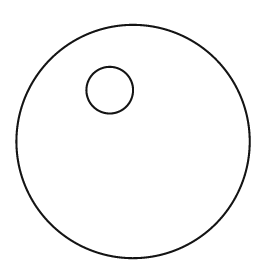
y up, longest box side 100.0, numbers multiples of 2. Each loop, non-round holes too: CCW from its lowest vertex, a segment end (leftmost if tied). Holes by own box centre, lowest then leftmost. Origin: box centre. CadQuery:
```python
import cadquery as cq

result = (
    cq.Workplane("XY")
    .moveTo(0.0, 0.0)
    .circle(50.0)
    .moveTo(-10.0, 22.0)
    .circle(10.0)
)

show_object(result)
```